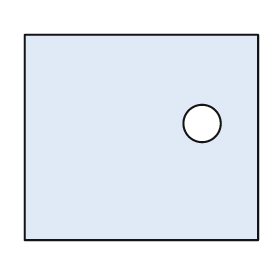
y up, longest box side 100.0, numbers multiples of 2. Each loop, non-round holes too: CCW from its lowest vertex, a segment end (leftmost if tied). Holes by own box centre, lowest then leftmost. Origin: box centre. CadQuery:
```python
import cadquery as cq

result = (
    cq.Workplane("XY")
    .moveTo(-50.0, -44.0)
    .lineTo(50.0, -44.0)
    .lineTo(50.0, 44.0)
    .lineTo(-50.0, 44.0)
    .close()
    .moveTo(26.0, 6.0)
    .circle(8.0)
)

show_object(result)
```